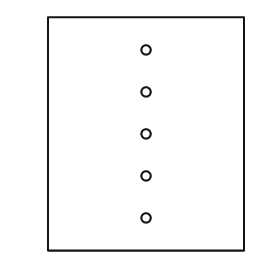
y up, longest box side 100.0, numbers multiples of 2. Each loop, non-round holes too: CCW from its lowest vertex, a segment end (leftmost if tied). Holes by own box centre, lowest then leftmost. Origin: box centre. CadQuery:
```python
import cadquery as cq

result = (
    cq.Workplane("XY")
    .moveTo(-42.0, -50.0)
    .lineTo(42.0, -50.0)
    .lineTo(42.0, 50.0)
    .lineTo(-42.0, 50.0)
    .close()
    .moveTo(0.0, -36.0)
    .circle(2.0)
    .moveTo(0.0, -18.0)
    .circle(2.0)
    .moveTo(0.0, 0.0)
    .circle(2.0)
    .moveTo(0.0, 18.0)
    .circle(2.0)
    .moveTo(0.0, 36.0)
    .circle(2.0)
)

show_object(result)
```